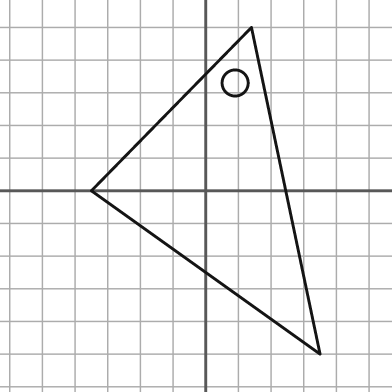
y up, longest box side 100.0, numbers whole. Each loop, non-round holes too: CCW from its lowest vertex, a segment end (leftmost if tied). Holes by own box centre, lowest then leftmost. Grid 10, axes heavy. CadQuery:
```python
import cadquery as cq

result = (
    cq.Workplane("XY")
    .moveTo(35.0, -50.0)
    .lineTo(14.0, 50.0)
    .lineTo(-35.0, 0.0)
    .close()
    .moveTo(9.0, 33.0)
    .circle(4.0)
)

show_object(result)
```